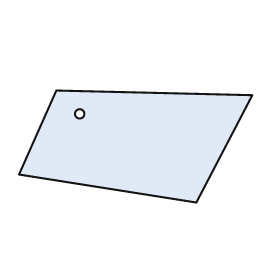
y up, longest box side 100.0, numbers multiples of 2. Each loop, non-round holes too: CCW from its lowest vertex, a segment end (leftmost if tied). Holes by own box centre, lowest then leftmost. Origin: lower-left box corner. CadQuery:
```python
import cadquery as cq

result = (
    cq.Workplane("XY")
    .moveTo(76.0, 0.0)
    .lineTo(100.0, 46.0)
    .lineTo(16.0, 48.0)
    .lineTo(0.0, 12.0)
    .close()
    .moveTo(26.0, 38.0)
    .circle(2.0)
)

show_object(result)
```